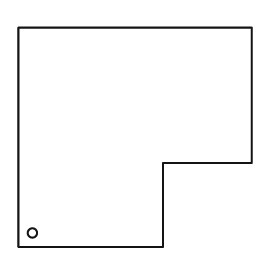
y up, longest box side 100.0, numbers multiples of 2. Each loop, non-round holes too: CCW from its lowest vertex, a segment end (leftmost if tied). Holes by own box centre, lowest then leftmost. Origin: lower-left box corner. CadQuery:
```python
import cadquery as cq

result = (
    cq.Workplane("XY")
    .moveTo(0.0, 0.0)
    .lineTo(62.0, 0.0)
    .lineTo(62.0, 36.0)
    .lineTo(100.0, 36.0)
    .lineTo(100.0, 94.0)
    .lineTo(0.0, 94.0)
    .close()
    .moveTo(6.0, 6.0)
    .circle(2.0)
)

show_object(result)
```